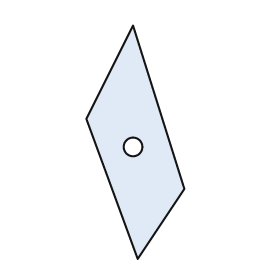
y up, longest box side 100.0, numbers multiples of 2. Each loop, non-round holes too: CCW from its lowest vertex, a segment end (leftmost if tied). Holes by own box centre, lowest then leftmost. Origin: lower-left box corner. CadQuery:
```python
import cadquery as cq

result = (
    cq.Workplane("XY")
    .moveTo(22.0, 0.0)
    .lineTo(42.0, 30.0)
    .lineTo(20.0, 100.0)
    .lineTo(0.0, 60.0)
    .close()
    .moveTo(20.0, 48.0)
    .circle(4.0)
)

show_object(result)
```